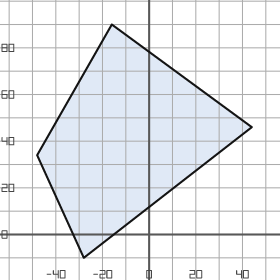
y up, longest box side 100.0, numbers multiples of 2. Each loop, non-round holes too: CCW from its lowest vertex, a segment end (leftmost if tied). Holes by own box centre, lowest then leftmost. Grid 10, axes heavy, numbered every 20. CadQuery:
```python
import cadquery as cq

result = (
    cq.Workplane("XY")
    .moveTo(-28.0, -10.0)
    .lineTo(44.0, 46.0)
    .lineTo(-16.0, 90.0)
    .lineTo(-48.0, 34.0)
    .close()
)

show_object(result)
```